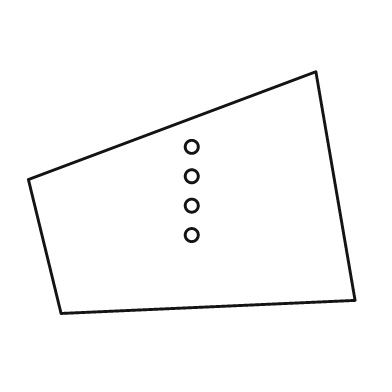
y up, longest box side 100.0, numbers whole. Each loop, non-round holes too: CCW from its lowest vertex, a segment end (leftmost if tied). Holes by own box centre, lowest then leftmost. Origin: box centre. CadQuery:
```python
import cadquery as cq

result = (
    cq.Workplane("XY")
    .moveTo(-40.0, -37.0)
    .lineTo(50.0, -33.0)
    .lineTo(38.0, 37.0)
    .lineTo(-50.0, 4.0)
    .close()
    .moveTo(0.0, -13.0)
    .circle(2.0)
    .moveTo(0.0, -4.0)
    .circle(2.0)
    .moveTo(0.0, 5.0)
    .circle(2.0)
    .moveTo(0.0, 14.0)
    .circle(2.0)
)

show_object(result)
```